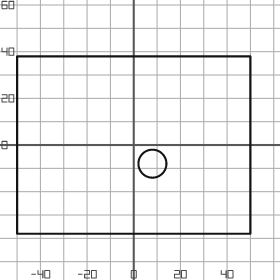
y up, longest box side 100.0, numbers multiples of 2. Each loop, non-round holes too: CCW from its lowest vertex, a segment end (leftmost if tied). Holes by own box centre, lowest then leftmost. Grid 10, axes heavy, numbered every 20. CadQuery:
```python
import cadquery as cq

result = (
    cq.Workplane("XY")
    .moveTo(-50.0, -38.0)
    .lineTo(50.0, -38.0)
    .lineTo(50.0, 38.0)
    .lineTo(-50.0, 38.0)
    .close()
    .moveTo(8.0, -8.0)
    .circle(6.0)
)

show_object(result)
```